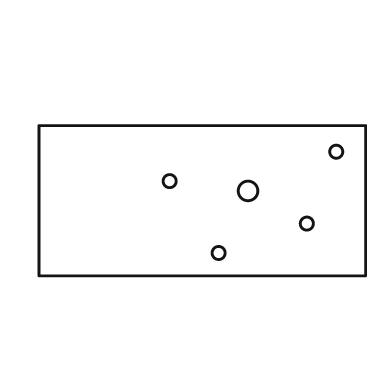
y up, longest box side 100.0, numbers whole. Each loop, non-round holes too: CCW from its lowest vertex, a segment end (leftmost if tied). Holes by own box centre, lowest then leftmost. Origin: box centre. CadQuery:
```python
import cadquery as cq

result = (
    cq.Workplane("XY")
    .moveTo(-50.0, -23.0)
    .lineTo(50.0, -23.0)
    .lineTo(50.0, 23.0)
    .lineTo(-50.0, 23.0)
    .close()
    .moveTo(5.0, -16.0)
    .circle(2.0)
    .moveTo(32.0, -7.0)
    .circle(2.0)
    .moveTo(14.0, 3.0)
    .circle(3.0)
    .moveTo(-10.0, 6.0)
    .circle(2.0)
    .moveTo(41.0, 15.0)
    .circle(2.0)
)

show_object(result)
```